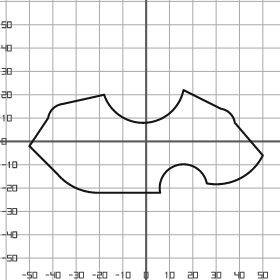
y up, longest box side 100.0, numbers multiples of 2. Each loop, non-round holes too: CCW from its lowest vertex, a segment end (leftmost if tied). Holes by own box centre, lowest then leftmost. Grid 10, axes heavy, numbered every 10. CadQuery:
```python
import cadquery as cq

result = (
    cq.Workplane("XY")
    .moveTo(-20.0, -22.0)
    .lineTo(6.0, -22.0)
    .threePointArc((14.0, -10.0), (26.0, -18.0))
    .threePointArc((40.0, -16.0), (50.0, -6.0))
    .lineTo(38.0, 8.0)
    .threePointArc((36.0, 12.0), (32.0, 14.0))
    .lineTo(16.0, 22.0)
    .threePointArc((0.0, 8.0), (-18.0, 20.0))
    .lineTo(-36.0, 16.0)
    .threePointArc((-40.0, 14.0), (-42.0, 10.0))
    .lineTo(-50.0, -2.0)
    .lineTo(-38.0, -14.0)
    .threePointArc((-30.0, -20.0), (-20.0, -22.0))
    .close()
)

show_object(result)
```